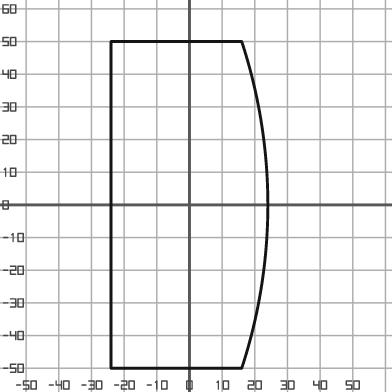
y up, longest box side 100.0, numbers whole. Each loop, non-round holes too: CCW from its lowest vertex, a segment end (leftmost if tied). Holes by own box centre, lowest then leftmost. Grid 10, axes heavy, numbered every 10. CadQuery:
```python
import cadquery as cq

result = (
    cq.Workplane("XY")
    .moveTo(-24.0, -50.0)
    .lineTo(16.0, -50.0)
    .threePointArc((24.0, 0.0), (16.0, 50.0))
    .lineTo(-24.0, 50.0)
    .close()
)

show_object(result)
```